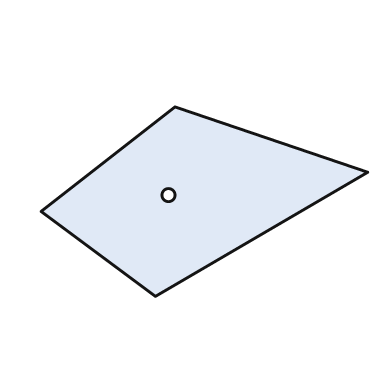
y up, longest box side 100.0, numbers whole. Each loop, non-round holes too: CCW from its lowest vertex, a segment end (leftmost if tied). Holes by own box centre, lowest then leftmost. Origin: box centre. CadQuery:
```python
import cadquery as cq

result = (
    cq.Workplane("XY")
    .moveTo(-15.0, -29.0)
    .lineTo(50.0, 9.0)
    .lineTo(-9.0, 29.0)
    .lineTo(-50.0, -3.0)
    .close()
    .moveTo(-11.0, 2.0)
    .circle(2.0)
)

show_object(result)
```